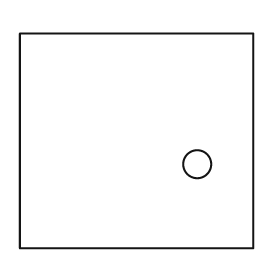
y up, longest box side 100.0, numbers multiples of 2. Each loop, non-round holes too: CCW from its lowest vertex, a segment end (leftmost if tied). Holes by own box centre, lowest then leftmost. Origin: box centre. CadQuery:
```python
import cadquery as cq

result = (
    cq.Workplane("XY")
    .moveTo(-50.0, -46.0)
    .lineTo(50.0, -46.0)
    .lineTo(50.0, 46.0)
    .lineTo(-50.0, 46.0)
    .close()
    .moveTo(26.0, -10.0)
    .circle(6.0)
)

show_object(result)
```